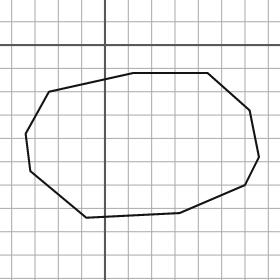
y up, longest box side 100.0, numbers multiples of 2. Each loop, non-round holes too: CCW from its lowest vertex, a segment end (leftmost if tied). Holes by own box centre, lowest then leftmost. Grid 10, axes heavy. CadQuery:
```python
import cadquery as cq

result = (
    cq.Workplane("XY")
    .moveTo(-8.0, -74.0)
    .lineTo(32.0, -72.0)
    .lineTo(60.0, -60.0)
    .lineTo(66.0, -48.0)
    .lineTo(62.0, -28.0)
    .lineTo(44.0, -12.0)
    .lineTo(12.0, -12.0)
    .lineTo(-24.0, -20.0)
    .lineTo(-34.0, -38.0)
    .lineTo(-32.0, -54.0)
    .close()
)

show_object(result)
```